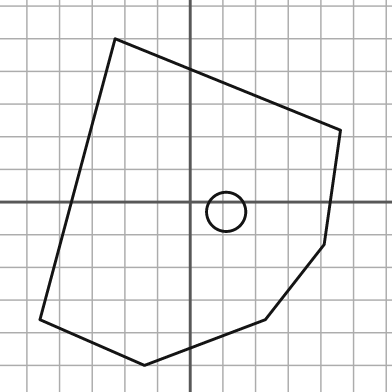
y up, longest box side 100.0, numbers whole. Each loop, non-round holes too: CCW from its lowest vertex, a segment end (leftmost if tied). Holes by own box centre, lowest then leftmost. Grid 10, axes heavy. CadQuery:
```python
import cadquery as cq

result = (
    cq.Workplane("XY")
    .moveTo(-14.0, -50.0)
    .lineTo(23.0, -36.0)
    .lineTo(41.0, -13.0)
    .lineTo(46.0, 22.0)
    .lineTo(-23.0, 50.0)
    .lineTo(-46.0, -36.0)
    .close()
    .moveTo(11.0, -3.0)
    .circle(6.0)
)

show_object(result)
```